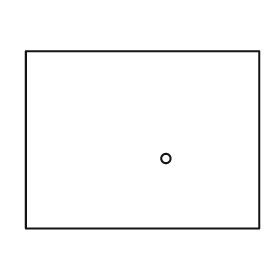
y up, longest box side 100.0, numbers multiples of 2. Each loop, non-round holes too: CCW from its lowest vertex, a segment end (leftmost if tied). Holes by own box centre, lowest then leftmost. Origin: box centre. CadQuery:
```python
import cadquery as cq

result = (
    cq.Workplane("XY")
    .moveTo(-50.0, -38.0)
    .lineTo(50.0, -38.0)
    .lineTo(50.0, 38.0)
    .lineTo(-50.0, 38.0)
    .close()
    .moveTo(10.0, -8.0)
    .circle(2.0)
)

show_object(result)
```